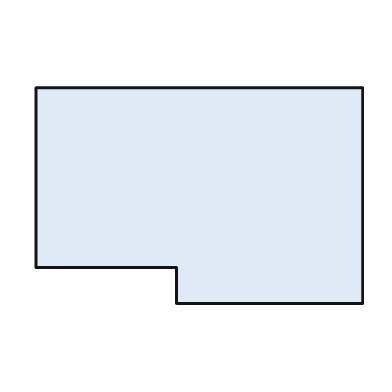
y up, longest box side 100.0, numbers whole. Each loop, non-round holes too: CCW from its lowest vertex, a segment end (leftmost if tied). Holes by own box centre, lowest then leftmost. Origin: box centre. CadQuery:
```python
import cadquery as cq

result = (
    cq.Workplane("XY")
    .moveTo(-7.0, -33.0)
    .lineTo(50.0, -33.0)
    .lineTo(50.0, 33.0)
    .lineTo(-50.0, 33.0)
    .lineTo(-50.0, -22.0)
    .lineTo(-7.0, -22.0)
    .close()
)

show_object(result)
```